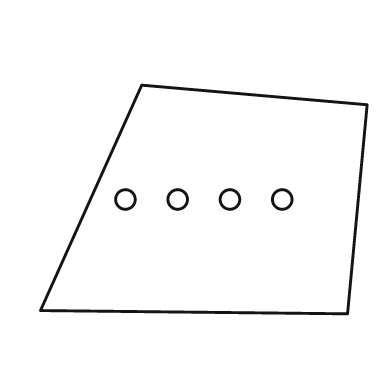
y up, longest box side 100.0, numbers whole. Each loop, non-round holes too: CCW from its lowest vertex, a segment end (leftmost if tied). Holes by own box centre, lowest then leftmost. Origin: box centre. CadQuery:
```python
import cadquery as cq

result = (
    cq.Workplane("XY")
    .moveTo(44.0, -35.0)
    .lineTo(50.0, 29.0)
    .lineTo(-19.0, 35.0)
    .lineTo(-50.0, -34.0)
    .close()
    .moveTo(-24.0, 0.0)
    .circle(3.0)
    .moveTo(-8.0, 0.0)
    .circle(3.0)
    .moveTo(8.0, 0.0)
    .circle(3.0)
    .moveTo(24.0, 0.0)
    .circle(3.0)
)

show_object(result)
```